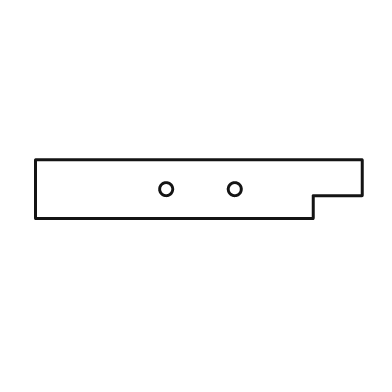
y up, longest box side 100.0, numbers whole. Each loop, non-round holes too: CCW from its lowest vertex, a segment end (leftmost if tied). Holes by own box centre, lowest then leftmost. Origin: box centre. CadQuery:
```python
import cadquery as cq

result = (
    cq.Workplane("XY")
    .moveTo(-50.0, -9.0)
    .lineTo(35.0, -9.0)
    .lineTo(35.0, -2.0)
    .lineTo(50.0, -2.0)
    .lineTo(50.0, 9.0)
    .lineTo(-50.0, 9.0)
    .close()
    .moveTo(-10.0, 0.0)
    .circle(2.0)
    .moveTo(11.0, 0.0)
    .circle(2.0)
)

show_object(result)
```